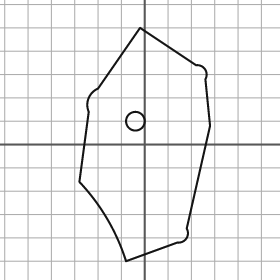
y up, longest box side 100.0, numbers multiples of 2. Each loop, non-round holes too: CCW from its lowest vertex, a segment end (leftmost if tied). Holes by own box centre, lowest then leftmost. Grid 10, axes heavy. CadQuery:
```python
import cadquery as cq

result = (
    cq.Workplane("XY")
    .moveTo(-8.0, -50.0)
    .lineTo(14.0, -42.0)
    .threePointArc((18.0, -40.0), (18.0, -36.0))
    .lineTo(28.0, 8.0)
    .lineTo(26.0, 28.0)
    .threePointArc((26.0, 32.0), (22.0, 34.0))
    .lineTo(-2.0, 50.0)
    .lineTo(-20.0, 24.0)
    .threePointArc((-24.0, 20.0), (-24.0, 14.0))
    .lineTo(-28.0, -16.0)
    .threePointArc((-16.0, -32.0), (-8.0, -50.0))
    .close()
    .moveTo(-4.0, 10.0)
    .circle(4.0)
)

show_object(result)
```